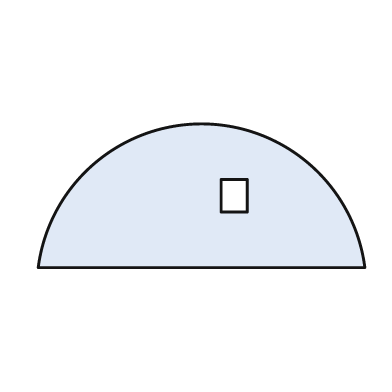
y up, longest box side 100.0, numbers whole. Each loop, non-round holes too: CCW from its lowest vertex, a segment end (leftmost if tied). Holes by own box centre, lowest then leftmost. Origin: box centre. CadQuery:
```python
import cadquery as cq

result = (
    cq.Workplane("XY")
    .moveTo(-50.0, -22.0)
    .lineTo(50.0, -22.0)
    .threePointArc((0.0, 22.0), (-50.0, -22.0))
    .close()
    .moveTo(6.0, -5.0)
    .lineTo(14.0, -5.0)
    .lineTo(14.0, 5.0)
    .lineTo(6.0, 5.0)
    .close()
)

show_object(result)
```